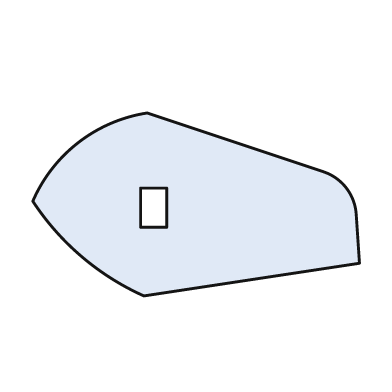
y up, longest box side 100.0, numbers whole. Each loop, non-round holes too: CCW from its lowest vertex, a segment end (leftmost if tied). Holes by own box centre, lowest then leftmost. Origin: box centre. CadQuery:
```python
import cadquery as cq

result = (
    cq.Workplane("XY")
    .moveTo(-16.0, -28.0)
    .lineTo(50.0, -18.0)
    .lineTo(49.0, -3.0)
    .threePointArc((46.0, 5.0), (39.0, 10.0))
    .lineTo(-15.0, 28.0)
    .threePointArc((-36.0, 19.0), (-50.0, 1.0))
    .threePointArc((-35.0, -16.0), (-16.0, -28.0))
    .close()
    .moveTo(-17.0, -7.0)
    .lineTo(-9.0, -7.0)
    .lineTo(-9.0, 5.0)
    .lineTo(-17.0, 5.0)
    .close()
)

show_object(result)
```